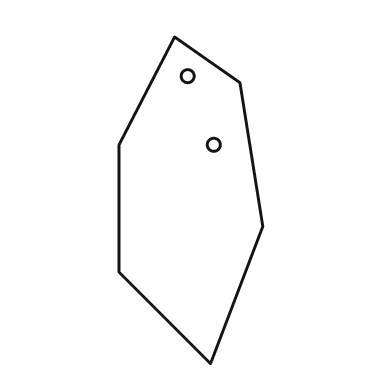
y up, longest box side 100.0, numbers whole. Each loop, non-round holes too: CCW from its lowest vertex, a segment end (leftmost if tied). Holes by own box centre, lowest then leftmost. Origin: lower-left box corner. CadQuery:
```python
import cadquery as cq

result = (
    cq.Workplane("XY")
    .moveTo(28.0, 0.0)
    .lineTo(44.0, 42.0)
    .lineTo(37.0, 86.0)
    .lineTo(17.0, 100.0)
    .lineTo(0.0, 67.0)
    .lineTo(0.0, 28.0)
    .close()
    .moveTo(29.0, 67.0)
    .circle(2.0)
    .moveTo(21.0, 88.0)
    .circle(2.0)
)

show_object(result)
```